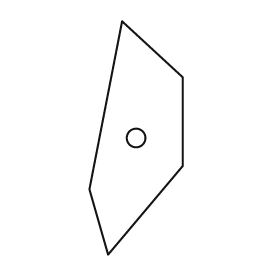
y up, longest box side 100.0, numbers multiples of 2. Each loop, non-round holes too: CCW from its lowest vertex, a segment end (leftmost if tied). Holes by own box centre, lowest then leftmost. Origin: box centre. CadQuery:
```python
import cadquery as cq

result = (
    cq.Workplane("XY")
    .moveTo(-12.0, -50.0)
    .lineTo(20.0, -12.0)
    .lineTo(20.0, 26.0)
    .lineTo(-6.0, 50.0)
    .lineTo(-20.0, -22.0)
    .close()
    .moveTo(0.0, 0.0)
    .circle(4.0)
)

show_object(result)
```